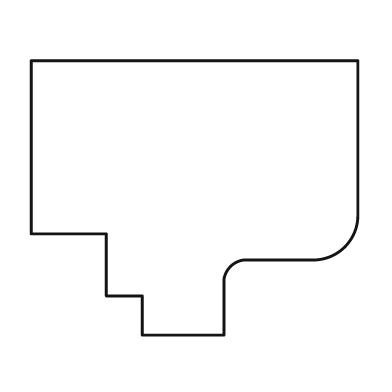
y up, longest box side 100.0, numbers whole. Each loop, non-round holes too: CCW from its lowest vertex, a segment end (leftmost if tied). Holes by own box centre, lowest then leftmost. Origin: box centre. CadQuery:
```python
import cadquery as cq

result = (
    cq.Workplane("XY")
    .moveTo(-16.0, -42.0)
    .lineTo(9.0, -42.0)
    .lineTo(9.0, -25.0)
    .threePointArc((11.0, -21.0), (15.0, -19.0))
    .lineTo(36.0, -19.0)
    .threePointArc((46.0, -15.0), (50.0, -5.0))
    .lineTo(50.0, 42.0)
    .lineTo(-50.0, 42.0)
    .lineTo(-50.0, -11.0)
    .lineTo(-27.0, -11.0)
    .lineTo(-27.0, -30.0)
    .lineTo(-16.0, -30.0)
    .close()
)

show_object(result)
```